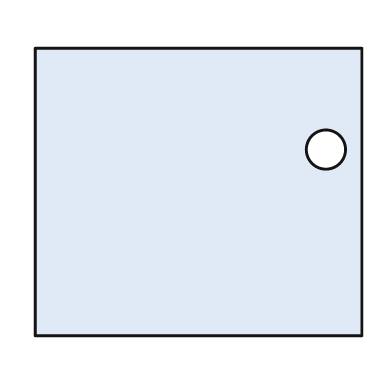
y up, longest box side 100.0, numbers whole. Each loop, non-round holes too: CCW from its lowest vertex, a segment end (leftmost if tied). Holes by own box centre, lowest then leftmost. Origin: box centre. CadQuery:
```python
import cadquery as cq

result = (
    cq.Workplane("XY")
    .moveTo(-50.0, -44.0)
    .lineTo(50.0, -44.0)
    .lineTo(50.0, 44.0)
    .lineTo(-50.0, 44.0)
    .close()
    .moveTo(39.0, 13.0)
    .circle(6.0)
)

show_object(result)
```